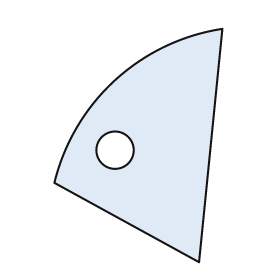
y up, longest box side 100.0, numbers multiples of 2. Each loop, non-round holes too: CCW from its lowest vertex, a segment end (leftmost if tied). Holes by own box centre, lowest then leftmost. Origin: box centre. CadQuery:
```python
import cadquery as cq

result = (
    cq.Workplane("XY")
    .moveTo(26.0, -50.0)
    .lineTo(36.0, 50.0)
    .threePointArc((-10.0, 28.0), (-36.0, -16.0))
    .close()
    .moveTo(-10.0, -2.0)
    .circle(8.0)
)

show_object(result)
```